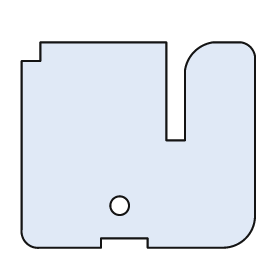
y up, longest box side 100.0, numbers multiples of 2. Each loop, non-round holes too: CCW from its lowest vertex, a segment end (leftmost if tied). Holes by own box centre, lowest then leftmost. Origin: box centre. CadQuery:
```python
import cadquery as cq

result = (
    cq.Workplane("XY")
    .moveTo(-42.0, -44.0)
    .lineTo(-16.0, -44.0)
    .lineTo(-16.0, -40.0)
    .lineTo(4.0, -40.0)
    .lineTo(4.0, -44.0)
    .lineTo(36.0, -44.0)
    .threePointArc((46.0, -40.0), (50.0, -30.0))
    .lineTo(50.0, 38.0)
    .threePointArc((48.0, 42.0), (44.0, 44.0))
    .lineTo(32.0, 44.0)
    .threePointArc((24.0, 40.0), (20.0, 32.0))
    .lineTo(20.0, 2.0)
    .lineTo(12.0, 2.0)
    .lineTo(12.0, 44.0)
    .lineTo(-42.0, 44.0)
    .lineTo(-42.0, 36.0)
    .lineTo(-50.0, 36.0)
    .lineTo(-50.0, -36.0)
    .threePointArc((-48.0, -42.0), (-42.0, -44.0))
    .close()
    .moveTo(-8.0, -26.0)
    .circle(4.0)
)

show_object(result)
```